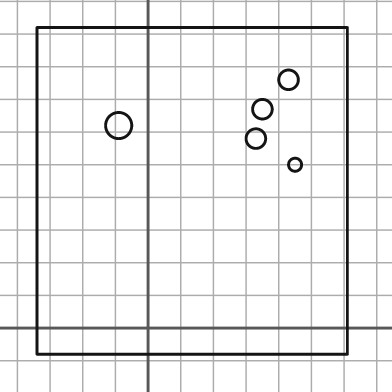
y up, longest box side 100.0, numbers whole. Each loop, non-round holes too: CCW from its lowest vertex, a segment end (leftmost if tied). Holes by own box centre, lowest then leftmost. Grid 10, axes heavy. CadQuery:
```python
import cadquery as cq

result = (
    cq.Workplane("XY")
    .moveTo(-34.0, -8.0)
    .lineTo(61.0, -8.0)
    .lineTo(61.0, 92.0)
    .lineTo(-34.0, 92.0)
    .close()
    .moveTo(45.0, 50.0)
    .circle(2.0)
    .moveTo(33.0, 58.0)
    .circle(3.0)
    .moveTo(-9.0, 62.0)
    .circle(4.0)
    .moveTo(35.0, 67.0)
    .circle(3.0)
    .moveTo(43.0, 76.0)
    .circle(3.0)
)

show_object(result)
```